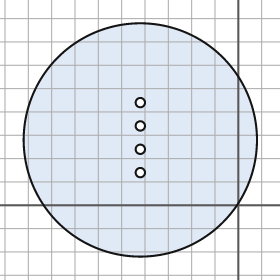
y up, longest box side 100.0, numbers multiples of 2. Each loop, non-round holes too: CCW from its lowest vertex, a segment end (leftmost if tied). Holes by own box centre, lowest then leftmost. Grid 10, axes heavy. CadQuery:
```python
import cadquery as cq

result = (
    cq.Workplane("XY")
    .moveTo(-42.0, 28.0)
    .circle(50.0)
    .moveTo(-42.0, 14.0)
    .circle(2.0)
    .moveTo(-42.0, 24.0)
    .circle(2.0)
    .moveTo(-42.0, 34.0)
    .circle(2.0)
    .moveTo(-42.0, 44.0)
    .circle(2.0)
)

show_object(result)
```